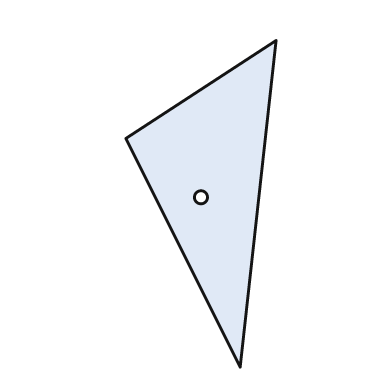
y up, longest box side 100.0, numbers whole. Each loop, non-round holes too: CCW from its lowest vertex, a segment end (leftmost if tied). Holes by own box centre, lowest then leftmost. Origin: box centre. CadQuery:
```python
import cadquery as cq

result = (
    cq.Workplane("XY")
    .moveTo(12.0, -50.0)
    .lineTo(23.0, 50.0)
    .lineTo(-23.0, 20.0)
    .close()
    .moveTo(0.0, 2.0)
    .circle(2.0)
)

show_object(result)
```